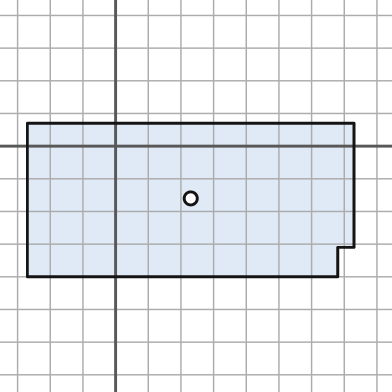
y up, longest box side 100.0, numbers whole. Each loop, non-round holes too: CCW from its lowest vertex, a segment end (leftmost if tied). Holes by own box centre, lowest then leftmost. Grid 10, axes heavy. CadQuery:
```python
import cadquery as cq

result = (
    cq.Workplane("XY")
    .moveTo(-27.0, -40.0)
    .lineTo(68.0, -40.0)
    .lineTo(68.0, -31.0)
    .lineTo(73.0, -31.0)
    .lineTo(73.0, 7.0)
    .lineTo(-27.0, 7.0)
    .close()
    .moveTo(23.0, -16.0)
    .circle(2.0)
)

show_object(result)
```